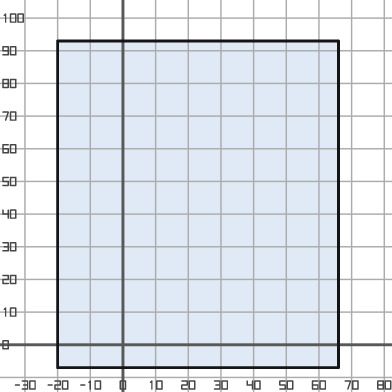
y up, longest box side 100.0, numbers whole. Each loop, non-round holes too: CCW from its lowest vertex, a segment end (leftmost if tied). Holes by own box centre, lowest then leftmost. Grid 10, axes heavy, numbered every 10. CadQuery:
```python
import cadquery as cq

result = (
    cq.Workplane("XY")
    .moveTo(-20.0, -7.0)
    .lineTo(66.0, -7.0)
    .lineTo(66.0, 93.0)
    .lineTo(-20.0, 93.0)
    .close()
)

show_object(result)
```